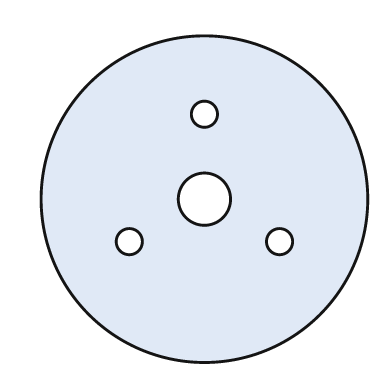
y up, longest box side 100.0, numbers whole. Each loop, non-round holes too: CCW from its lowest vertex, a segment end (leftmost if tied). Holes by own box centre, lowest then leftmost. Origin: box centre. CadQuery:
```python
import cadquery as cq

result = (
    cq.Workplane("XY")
    .moveTo(0.0, 0.0)
    .circle(50.0)
    .moveTo(-23.0, -13.0)
    .circle(4.0)
    .moveTo(23.0, -13.0)
    .circle(4.0)
    .moveTo(0.0, 0.0)
    .circle(8.0)
    .moveTo(0.0, 26.0)
    .circle(4.0)
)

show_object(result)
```